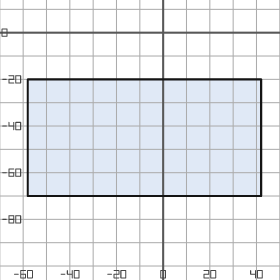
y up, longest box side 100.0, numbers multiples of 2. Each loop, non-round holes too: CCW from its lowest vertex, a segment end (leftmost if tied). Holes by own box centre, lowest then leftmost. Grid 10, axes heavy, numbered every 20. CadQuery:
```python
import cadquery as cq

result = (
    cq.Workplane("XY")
    .moveTo(-58.0, -70.0)
    .lineTo(42.0, -70.0)
    .lineTo(42.0, -20.0)
    .lineTo(-58.0, -20.0)
    .close()
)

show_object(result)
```